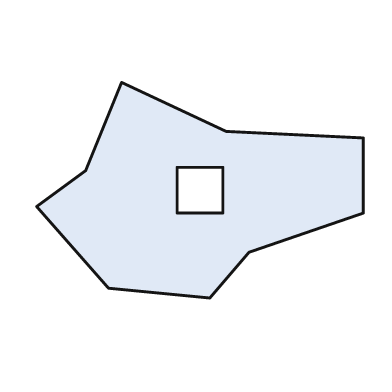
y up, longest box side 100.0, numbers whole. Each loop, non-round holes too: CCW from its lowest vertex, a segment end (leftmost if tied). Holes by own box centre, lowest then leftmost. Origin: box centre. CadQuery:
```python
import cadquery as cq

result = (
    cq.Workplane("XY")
    .moveTo(3.0, -33.0)
    .lineTo(15.0, -19.0)
    .lineTo(50.0, -7.0)
    .lineTo(50.0, 16.0)
    .lineTo(8.0, 18.0)
    .lineTo(-24.0, 33.0)
    .lineTo(-35.0, 6.0)
    .lineTo(-50.0, -5.0)
    .lineTo(-28.0, -30.0)
    .close()
    .moveTo(-7.0, -7.0)
    .lineTo(7.0, -7.0)
    .lineTo(7.0, 7.0)
    .lineTo(-7.0, 7.0)
    .close()
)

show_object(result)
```